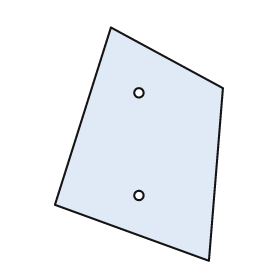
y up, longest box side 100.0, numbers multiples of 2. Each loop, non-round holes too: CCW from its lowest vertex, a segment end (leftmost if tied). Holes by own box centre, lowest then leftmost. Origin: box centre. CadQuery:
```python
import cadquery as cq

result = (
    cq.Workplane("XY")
    .moveTo(30.0, -50.0)
    .lineTo(36.0, 24.0)
    .lineTo(-12.0, 50.0)
    .lineTo(-36.0, -26.0)
    .close()
    .moveTo(0.0, -22.0)
    .circle(2.0)
    .moveTo(0.0, 22.0)
    .circle(2.0)
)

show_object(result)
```